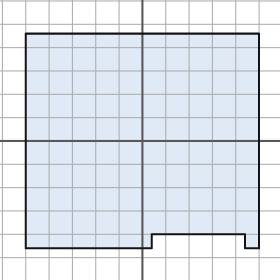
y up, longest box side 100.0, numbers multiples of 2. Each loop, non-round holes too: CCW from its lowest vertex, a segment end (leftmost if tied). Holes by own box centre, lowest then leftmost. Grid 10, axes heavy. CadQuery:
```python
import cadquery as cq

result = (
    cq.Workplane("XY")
    .moveTo(-50.0, -46.0)
    .lineTo(4.0, -46.0)
    .lineTo(4.0, -40.0)
    .lineTo(44.0, -40.0)
    .lineTo(44.0, -46.0)
    .lineTo(50.0, -46.0)
    .lineTo(50.0, 46.0)
    .lineTo(-50.0, 46.0)
    .close()
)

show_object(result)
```